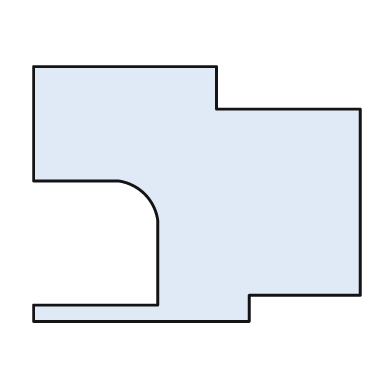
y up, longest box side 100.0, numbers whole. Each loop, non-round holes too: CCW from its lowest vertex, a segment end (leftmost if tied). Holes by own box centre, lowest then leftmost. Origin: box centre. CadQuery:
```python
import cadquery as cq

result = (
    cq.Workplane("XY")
    .moveTo(-50.0, -39.0)
    .lineTo(16.0, -39.0)
    .lineTo(16.0, -31.0)
    .lineTo(50.0, -31.0)
    .lineTo(50.0, 26.0)
    .lineTo(6.0, 26.0)
    .lineTo(6.0, 39.0)
    .lineTo(-50.0, 39.0)
    .lineTo(-50.0, 4.0)
    .lineTo(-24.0, 4.0)
    .threePointArc((-16.0, 0.0), (-12.0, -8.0))
    .lineTo(-12.0, -34.0)
    .lineTo(-50.0, -34.0)
    .close()
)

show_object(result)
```